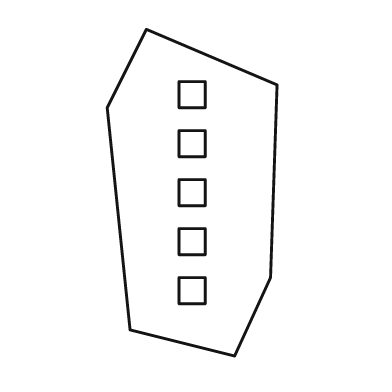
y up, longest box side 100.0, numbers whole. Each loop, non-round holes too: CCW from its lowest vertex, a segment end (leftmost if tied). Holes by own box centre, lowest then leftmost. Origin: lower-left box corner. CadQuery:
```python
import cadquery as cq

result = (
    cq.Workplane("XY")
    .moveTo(39.0, 0.0)
    .lineTo(50.0, 24.0)
    .lineTo(52.0, 83.0)
    .lineTo(12.0, 100.0)
    .lineTo(0.0, 76.0)
    .lineTo(7.0, 8.0)
    .close()
    .moveTo(22.0, 16.0)
    .lineTo(30.0, 16.0)
    .lineTo(30.0, 24.0)
    .lineTo(22.0, 24.0)
    .close()
    .moveTo(22.0, 31.0)
    .lineTo(30.0, 31.0)
    .lineTo(30.0, 39.0)
    .lineTo(22.0, 39.0)
    .close()
    .moveTo(22.0, 46.0)
    .lineTo(30.0, 46.0)
    .lineTo(30.0, 54.0)
    .lineTo(22.0, 54.0)
    .close()
    .moveTo(22.0, 61.0)
    .lineTo(30.0, 61.0)
    .lineTo(30.0, 69.0)
    .lineTo(22.0, 69.0)
    .close()
    .moveTo(22.0, 76.0)
    .lineTo(30.0, 76.0)
    .lineTo(30.0, 84.0)
    .lineTo(22.0, 84.0)
    .close()
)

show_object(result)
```